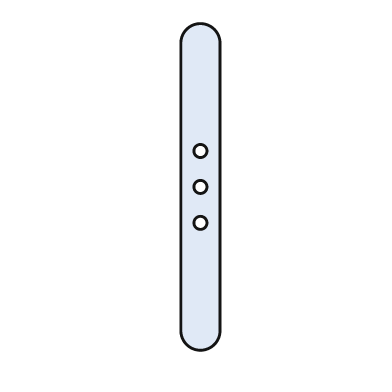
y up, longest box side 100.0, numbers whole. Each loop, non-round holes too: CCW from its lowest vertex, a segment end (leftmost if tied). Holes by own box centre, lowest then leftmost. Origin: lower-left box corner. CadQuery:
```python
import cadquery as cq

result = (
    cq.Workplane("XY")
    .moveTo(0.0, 6.0)
    .threePointArc((6.0, 0.0), (12.0, 6.0))
    .lineTo(12.0, 94.0)
    .threePointArc((6.0, 100.0), (0.0, 94.0))
    .close()
    .moveTo(6.0, 39.0)
    .circle(2.0)
    .moveTo(6.0, 50.0)
    .circle(2.0)
    .moveTo(6.0, 61.0)
    .circle(2.0)
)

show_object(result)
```